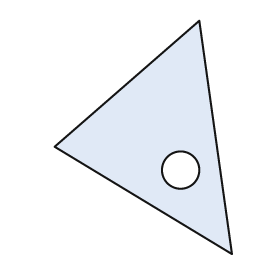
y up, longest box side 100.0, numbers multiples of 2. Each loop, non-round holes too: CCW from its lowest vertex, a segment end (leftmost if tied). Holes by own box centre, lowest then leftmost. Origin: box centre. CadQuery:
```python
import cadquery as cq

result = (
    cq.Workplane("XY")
    .moveTo(38.0, -50.0)
    .lineTo(24.0, 50.0)
    .lineTo(-38.0, -4.0)
    .close()
    .moveTo(16.0, -14.0)
    .circle(8.0)
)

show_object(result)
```